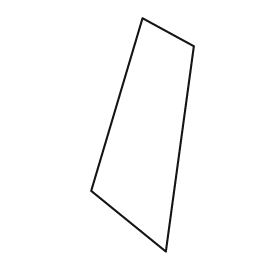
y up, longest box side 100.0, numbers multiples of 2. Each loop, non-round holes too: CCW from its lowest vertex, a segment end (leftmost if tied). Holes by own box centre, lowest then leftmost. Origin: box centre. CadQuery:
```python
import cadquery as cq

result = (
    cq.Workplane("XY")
    .moveTo(10.0, -50.0)
    .lineTo(22.0, 38.0)
    .lineTo(0.0, 50.0)
    .lineTo(-22.0, -24.0)
    .close()
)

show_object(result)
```